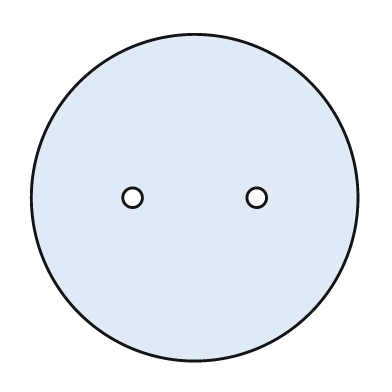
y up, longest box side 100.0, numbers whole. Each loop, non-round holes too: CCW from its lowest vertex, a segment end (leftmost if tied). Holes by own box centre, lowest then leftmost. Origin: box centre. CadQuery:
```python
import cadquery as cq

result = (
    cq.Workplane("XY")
    .moveTo(0.0, 0.0)
    .circle(50.0)
    .moveTo(-19.0, 0.0)
    .circle(3.0)
    .moveTo(19.0, 0.0)
    .circle(3.0)
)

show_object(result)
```